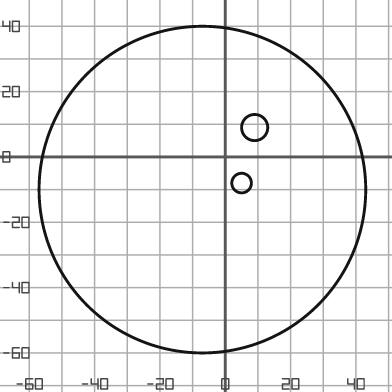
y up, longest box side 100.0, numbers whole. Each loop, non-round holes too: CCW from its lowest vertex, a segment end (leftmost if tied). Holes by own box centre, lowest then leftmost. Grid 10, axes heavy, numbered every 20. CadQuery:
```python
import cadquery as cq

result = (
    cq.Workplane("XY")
    .moveTo(-7.0, -10.0)
    .circle(50.0)
    .moveTo(5.0, -8.0)
    .circle(3.0)
    .moveTo(9.0, 9.0)
    .circle(4.0)
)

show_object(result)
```